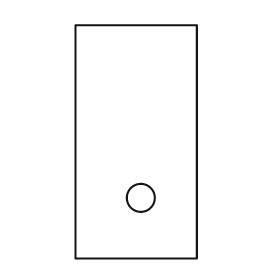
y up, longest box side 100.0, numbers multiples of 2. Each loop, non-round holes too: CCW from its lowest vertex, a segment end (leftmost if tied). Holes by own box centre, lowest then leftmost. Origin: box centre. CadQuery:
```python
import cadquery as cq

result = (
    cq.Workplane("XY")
    .moveTo(-26.0, -50.0)
    .lineTo(26.0, -50.0)
    .lineTo(26.0, 50.0)
    .lineTo(-26.0, 50.0)
    .close()
    .moveTo(2.0, -24.0)
    .circle(6.0)
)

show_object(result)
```